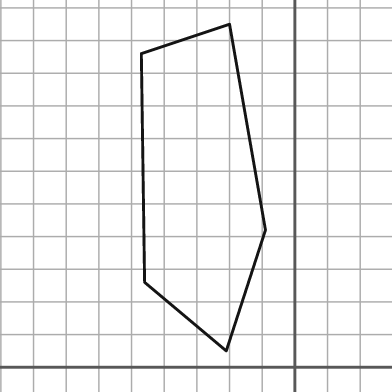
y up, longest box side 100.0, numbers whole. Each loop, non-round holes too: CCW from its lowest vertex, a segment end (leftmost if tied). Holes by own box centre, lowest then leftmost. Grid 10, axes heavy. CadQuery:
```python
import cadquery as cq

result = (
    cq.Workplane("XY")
    .moveTo(-21.0, 5.0)
    .lineTo(-9.0, 42.0)
    .lineTo(-20.0, 105.0)
    .lineTo(-47.0, 96.0)
    .lineTo(-46.0, 26.0)
    .close()
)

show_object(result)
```